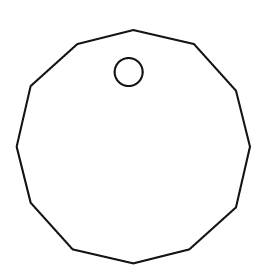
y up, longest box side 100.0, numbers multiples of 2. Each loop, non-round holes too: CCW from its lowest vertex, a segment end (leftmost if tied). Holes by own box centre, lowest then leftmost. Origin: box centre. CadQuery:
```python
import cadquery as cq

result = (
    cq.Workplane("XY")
    .moveTo(0.0, -50.0)
    .lineTo(24.0, -44.0)
    .lineTo(44.0, -26.0)
    .lineTo(50.0, 0.0)
    .lineTo(44.0, 24.0)
    .lineTo(26.0, 44.0)
    .lineTo(0.0, 50.0)
    .lineTo(-24.0, 44.0)
    .lineTo(-44.0, 26.0)
    .lineTo(-50.0, 0.0)
    .lineTo(-44.0, -24.0)
    .lineTo(-26.0, -44.0)
    .close()
    .moveTo(-2.0, 32.0)
    .circle(6.0)
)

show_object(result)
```